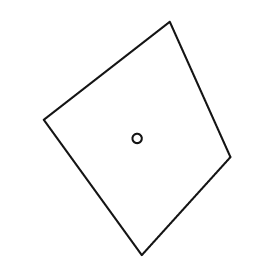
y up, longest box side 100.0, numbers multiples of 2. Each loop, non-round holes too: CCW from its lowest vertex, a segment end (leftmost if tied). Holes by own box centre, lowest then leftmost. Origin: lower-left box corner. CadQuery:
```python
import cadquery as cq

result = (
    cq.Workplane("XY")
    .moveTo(42.0, 0.0)
    .lineTo(80.0, 42.0)
    .lineTo(54.0, 100.0)
    .lineTo(0.0, 58.0)
    .close()
    .moveTo(40.0, 50.0)
    .circle(2.0)
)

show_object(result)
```